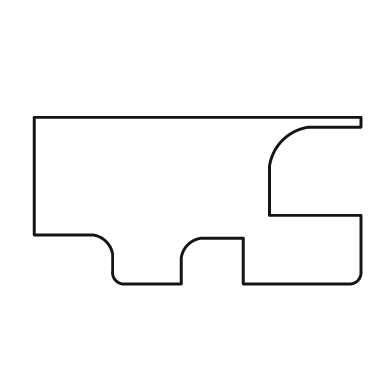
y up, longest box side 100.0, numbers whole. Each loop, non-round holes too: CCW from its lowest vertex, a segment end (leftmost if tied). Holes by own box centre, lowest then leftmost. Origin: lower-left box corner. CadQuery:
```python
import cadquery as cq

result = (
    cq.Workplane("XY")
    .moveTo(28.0, 0.0)
    .lineTo(45.0, 0.0)
    .lineTo(45.0, 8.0)
    .threePointArc((47.0, 12.0), (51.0, 14.0))
    .lineTo(64.0, 14.0)
    .lineTo(64.0, 0.0)
    .lineTo(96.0, 0.0)
    .threePointArc((99.0, 1.0), (100.0, 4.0))
    .lineTo(100.0, 21.0)
    .lineTo(72.0, 21.0)
    .lineTo(72.0, 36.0)
    .threePointArc((76.0, 44.0), (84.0, 48.0))
    .lineTo(100.0, 48.0)
    .lineTo(100.0, 51.0)
    .lineTo(0.0, 51.0)
    .lineTo(0.0, 15.0)
    .lineTo(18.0, 15.0)
    .threePointArc((22.0, 13.0), (24.0, 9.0))
    .lineTo(24.0, 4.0)
    .threePointArc((25.0, 1.0), (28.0, 0.0))
    .close()
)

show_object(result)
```